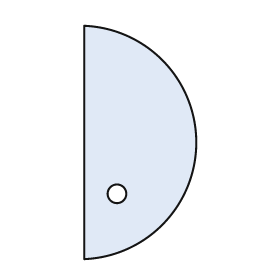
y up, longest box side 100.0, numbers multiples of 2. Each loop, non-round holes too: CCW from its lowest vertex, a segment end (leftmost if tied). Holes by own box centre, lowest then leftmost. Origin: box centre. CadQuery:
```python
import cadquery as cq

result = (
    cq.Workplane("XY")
    .moveTo(-24.0, -50.0)
    .threePointArc((24.0, 0.0), (-24.0, 50.0))
    .close()
    .moveTo(-10.0, -22.0)
    .circle(4.0)
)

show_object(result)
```